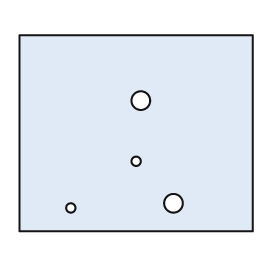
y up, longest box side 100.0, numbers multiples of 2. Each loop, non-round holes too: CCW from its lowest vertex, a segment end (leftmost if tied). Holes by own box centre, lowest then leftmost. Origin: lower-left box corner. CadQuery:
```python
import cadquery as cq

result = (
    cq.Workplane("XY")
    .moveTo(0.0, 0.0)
    .lineTo(100.0, 0.0)
    .lineTo(100.0, 84.0)
    .lineTo(0.0, 84.0)
    .close()
    .moveTo(22.0, 10.0)
    .circle(2.0)
    .moveTo(66.0, 12.0)
    .circle(4.0)
    .moveTo(50.0, 30.0)
    .circle(2.0)
    .moveTo(52.0, 56.0)
    .circle(4.0)
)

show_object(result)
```